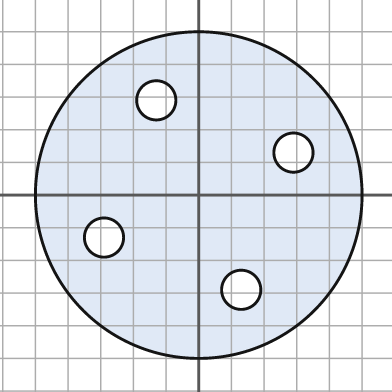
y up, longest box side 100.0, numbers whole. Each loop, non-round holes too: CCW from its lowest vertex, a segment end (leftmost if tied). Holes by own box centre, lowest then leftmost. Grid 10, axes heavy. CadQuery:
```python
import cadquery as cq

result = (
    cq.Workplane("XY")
    .moveTo(0.0, 0.0)
    .circle(50.0)
    .moveTo(13.0, -29.0)
    .circle(6.0)
    .moveTo(-29.0, -13.0)
    .circle(6.0)
    .moveTo(29.0, 13.0)
    .circle(6.0)
    .moveTo(-13.0, 29.0)
    .circle(6.0)
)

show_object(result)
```